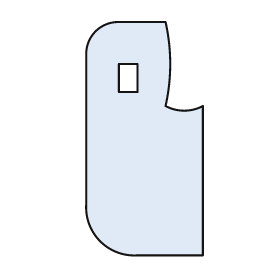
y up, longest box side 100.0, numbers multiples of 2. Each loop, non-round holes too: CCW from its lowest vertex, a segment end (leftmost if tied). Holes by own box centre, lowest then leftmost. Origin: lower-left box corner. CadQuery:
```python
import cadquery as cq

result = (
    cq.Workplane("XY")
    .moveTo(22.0, 0.0)
    .lineTo(50.0, 0.0)
    .lineTo(50.0, 64.0)
    .threePointArc((42.0, 62.0), (34.0, 64.0))
    .threePointArc((36.0, 82.0), (34.0, 100.0))
    .lineTo(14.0, 100.0)
    .threePointArc((4.0, 96.0), (0.0, 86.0))
    .lineTo(0.0, 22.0)
    .threePointArc((6.0, 6.0), (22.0, 0.0))
    .close()
    .moveTo(14.0, 70.0)
    .lineTo(22.0, 70.0)
    .lineTo(22.0, 82.0)
    .lineTo(14.0, 82.0)
    .close()
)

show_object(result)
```